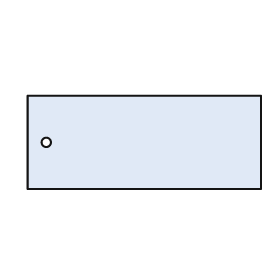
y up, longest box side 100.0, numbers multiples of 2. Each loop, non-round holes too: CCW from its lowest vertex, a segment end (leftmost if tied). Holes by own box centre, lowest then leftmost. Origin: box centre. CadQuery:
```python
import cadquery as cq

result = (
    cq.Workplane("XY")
    .moveTo(-50.0, -20.0)
    .lineTo(50.0, -20.0)
    .lineTo(50.0, 20.0)
    .lineTo(-50.0, 20.0)
    .close()
    .moveTo(-42.0, 0.0)
    .circle(2.0)
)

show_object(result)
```